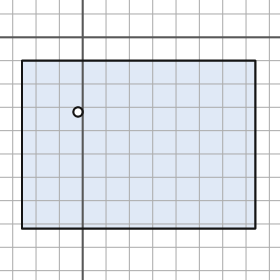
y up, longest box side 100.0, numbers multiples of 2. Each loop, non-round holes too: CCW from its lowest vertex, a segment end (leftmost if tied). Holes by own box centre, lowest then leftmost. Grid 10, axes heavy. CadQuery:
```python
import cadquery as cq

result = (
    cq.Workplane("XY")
    .moveTo(-26.0, -82.0)
    .lineTo(74.0, -82.0)
    .lineTo(74.0, -10.0)
    .lineTo(-26.0, -10.0)
    .close()
    .moveTo(-2.0, -32.0)
    .circle(2.0)
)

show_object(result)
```